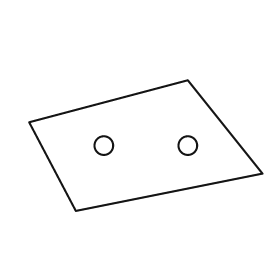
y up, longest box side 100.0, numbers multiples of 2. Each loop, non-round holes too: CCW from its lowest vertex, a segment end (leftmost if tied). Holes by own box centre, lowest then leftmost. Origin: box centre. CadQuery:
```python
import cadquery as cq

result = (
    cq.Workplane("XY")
    .moveTo(-30.0, -28.0)
    .lineTo(50.0, -12.0)
    .lineTo(18.0, 28.0)
    .lineTo(-50.0, 10.0)
    .close()
    .moveTo(-18.0, 0.0)
    .circle(4.0)
    .moveTo(18.0, 0.0)
    .circle(4.0)
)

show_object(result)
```